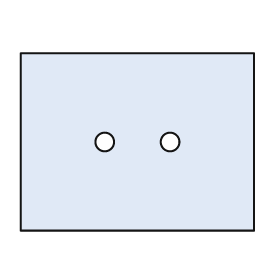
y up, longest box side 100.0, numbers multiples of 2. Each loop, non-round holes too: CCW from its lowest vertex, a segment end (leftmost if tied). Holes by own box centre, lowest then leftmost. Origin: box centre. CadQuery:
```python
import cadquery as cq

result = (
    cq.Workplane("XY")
    .moveTo(-50.0, -38.0)
    .lineTo(50.0, -38.0)
    .lineTo(50.0, 38.0)
    .lineTo(-50.0, 38.0)
    .close()
    .moveTo(-14.0, 0.0)
    .circle(4.0)
    .moveTo(14.0, 0.0)
    .circle(4.0)
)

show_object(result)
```